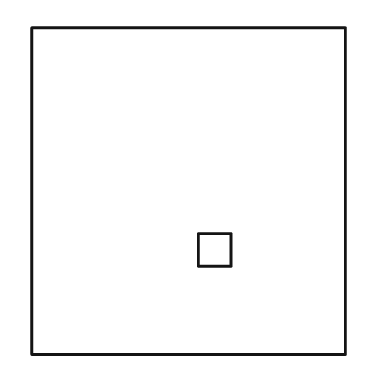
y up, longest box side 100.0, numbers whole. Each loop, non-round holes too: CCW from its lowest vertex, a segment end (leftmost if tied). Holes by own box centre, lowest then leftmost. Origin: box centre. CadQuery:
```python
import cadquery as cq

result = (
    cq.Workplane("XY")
    .moveTo(-48.0, -50.0)
    .lineTo(48.0, -50.0)
    .lineTo(48.0, 50.0)
    .lineTo(-48.0, 50.0)
    .close()
    .moveTo(3.0, -23.0)
    .lineTo(13.0, -23.0)
    .lineTo(13.0, -13.0)
    .lineTo(3.0, -13.0)
    .close()
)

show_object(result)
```